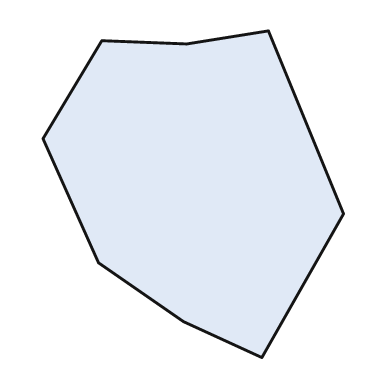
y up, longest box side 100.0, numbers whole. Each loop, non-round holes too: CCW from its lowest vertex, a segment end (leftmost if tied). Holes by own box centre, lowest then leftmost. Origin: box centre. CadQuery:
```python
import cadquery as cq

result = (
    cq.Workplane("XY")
    .moveTo(21.0, -50.0)
    .lineTo(46.0, -6.0)
    .lineTo(23.0, 50.0)
    .lineTo(-2.0, 46.0)
    .lineTo(-28.0, 47.0)
    .lineTo(-46.0, 17.0)
    .lineTo(-29.0, -21.0)
    .lineTo(-3.0, -39.0)
    .close()
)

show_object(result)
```